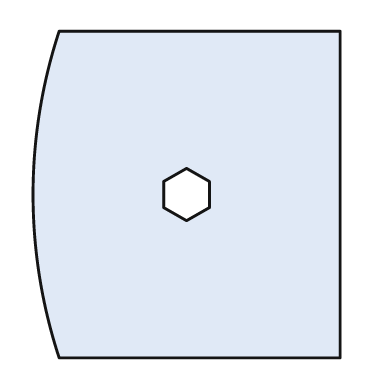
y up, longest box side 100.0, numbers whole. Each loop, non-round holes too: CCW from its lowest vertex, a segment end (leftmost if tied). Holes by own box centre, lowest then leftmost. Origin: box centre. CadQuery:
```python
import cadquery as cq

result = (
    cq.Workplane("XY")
    .moveTo(-39.0, -50.0)
    .lineTo(47.0, -50.0)
    .lineTo(47.0, 50.0)
    .lineTo(-39.0, 50.0)
    .threePointArc((-47.0, 0.0), (-39.0, -50.0))
    .close()
    .moveTo(0.0, -8.0)
    .lineTo(7.0, -4.0)
    .lineTo(7.0, 4.0)
    .lineTo(0.0, 8.0)
    .lineTo(-7.0, 4.0)
    .lineTo(-7.0, -4.0)
    .close()
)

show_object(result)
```